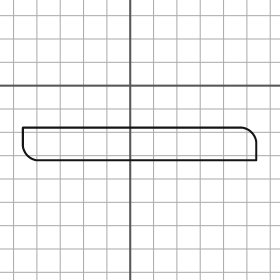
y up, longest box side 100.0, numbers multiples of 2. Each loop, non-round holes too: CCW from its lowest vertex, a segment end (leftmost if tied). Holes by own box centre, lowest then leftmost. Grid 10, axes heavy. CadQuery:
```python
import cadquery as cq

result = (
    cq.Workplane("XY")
    .moveTo(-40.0, -32.0)
    .lineTo(54.0, -32.0)
    .lineTo(54.0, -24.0)
    .threePointArc((52.0, -20.0), (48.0, -18.0))
    .lineTo(-46.0, -18.0)
    .lineTo(-46.0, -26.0)
    .threePointArc((-44.0, -30.0), (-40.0, -32.0))
    .close()
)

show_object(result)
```